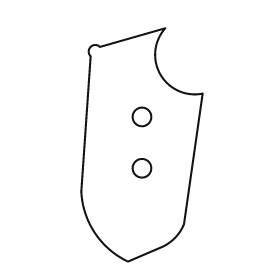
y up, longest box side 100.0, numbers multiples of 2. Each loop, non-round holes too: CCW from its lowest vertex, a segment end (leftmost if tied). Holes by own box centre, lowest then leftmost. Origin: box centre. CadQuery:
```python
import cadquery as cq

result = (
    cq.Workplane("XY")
    .moveTo(-6.0, -50.0)
    .lineTo(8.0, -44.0)
    .threePointArc((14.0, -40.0), (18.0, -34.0))
    .lineTo(26.0, 22.0)
    .threePointArc((8.0, 30.0), (10.0, 50.0))
    .lineTo(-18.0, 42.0)
    .threePointArc((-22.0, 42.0), (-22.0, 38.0))
    .lineTo(-26.0, -20.0)
    .threePointArc((-20.0, -38.0), (-6.0, -50.0))
    .close()
    .moveTo(0.0, -10.0)
    .circle(4.0)
    .moveTo(0.0, 12.0)
    .circle(4.0)
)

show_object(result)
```